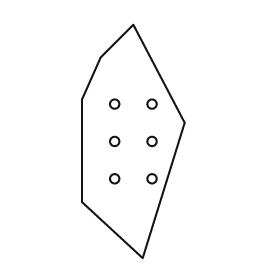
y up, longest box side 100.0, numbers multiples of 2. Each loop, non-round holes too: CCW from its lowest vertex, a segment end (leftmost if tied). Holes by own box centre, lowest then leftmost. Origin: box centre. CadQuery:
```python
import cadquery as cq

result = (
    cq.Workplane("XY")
    .moveTo(4.0, -50.0)
    .lineTo(22.0, 8.0)
    .lineTo(0.0, 50.0)
    .lineTo(-14.0, 36.0)
    .lineTo(-22.0, 18.0)
    .lineTo(-22.0, -26.0)
    .close()
    .moveTo(-8.0, -16.0)
    .circle(2.0)
    .moveTo(8.0, -16.0)
    .circle(2.0)
    .moveTo(-8.0, 0.0)
    .circle(2.0)
    .moveTo(8.0, 0.0)
    .circle(2.0)
    .moveTo(-8.0, 16.0)
    .circle(2.0)
    .moveTo(8.0, 16.0)
    .circle(2.0)
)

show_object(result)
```